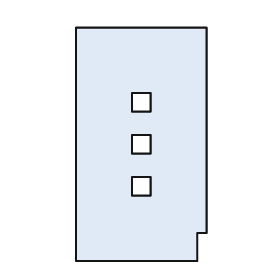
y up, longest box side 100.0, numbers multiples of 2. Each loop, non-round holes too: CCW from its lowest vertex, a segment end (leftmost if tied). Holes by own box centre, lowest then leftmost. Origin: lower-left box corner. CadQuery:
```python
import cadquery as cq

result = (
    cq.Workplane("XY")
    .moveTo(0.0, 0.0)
    .lineTo(52.0, 0.0)
    .lineTo(52.0, 12.0)
    .lineTo(56.0, 12.0)
    .lineTo(56.0, 100.0)
    .lineTo(0.0, 100.0)
    .close()
    .moveTo(24.0, 28.0)
    .lineTo(32.0, 28.0)
    .lineTo(32.0, 36.0)
    .lineTo(24.0, 36.0)
    .close()
    .moveTo(24.0, 46.0)
    .lineTo(32.0, 46.0)
    .lineTo(32.0, 54.0)
    .lineTo(24.0, 54.0)
    .close()
    .moveTo(24.0, 64.0)
    .lineTo(32.0, 64.0)
    .lineTo(32.0, 72.0)
    .lineTo(24.0, 72.0)
    .close()
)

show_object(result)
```